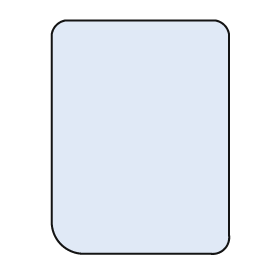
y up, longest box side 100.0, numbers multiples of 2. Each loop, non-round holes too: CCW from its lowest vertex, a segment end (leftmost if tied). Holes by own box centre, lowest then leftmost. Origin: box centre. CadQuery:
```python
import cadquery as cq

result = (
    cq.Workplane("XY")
    .moveTo(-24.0, -50.0)
    .lineTo(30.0, -50.0)
    .threePointArc((36.0, -48.0), (38.0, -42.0))
    .lineTo(38.0, 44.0)
    .threePointArc((36.0, 48.0), (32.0, 50.0))
    .lineTo(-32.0, 50.0)
    .threePointArc((-36.0, 48.0), (-38.0, 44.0))
    .lineTo(-38.0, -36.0)
    .threePointArc((-34.0, -46.0), (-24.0, -50.0))
    .close()
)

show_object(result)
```